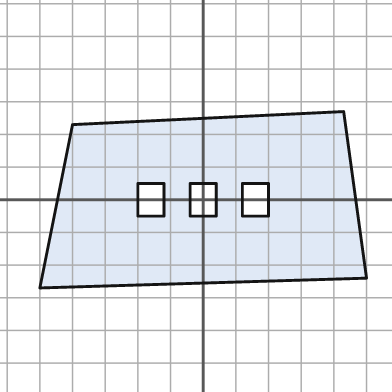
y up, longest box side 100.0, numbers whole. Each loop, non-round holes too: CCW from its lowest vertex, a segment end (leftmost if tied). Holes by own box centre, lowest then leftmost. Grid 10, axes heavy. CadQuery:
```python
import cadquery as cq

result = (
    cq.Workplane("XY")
    .moveTo(-50.0, -27.0)
    .lineTo(50.0, -24.0)
    .lineTo(43.0, 27.0)
    .lineTo(-40.0, 23.0)
    .close()
    .moveTo(-20.0, -5.0)
    .lineTo(-12.0, -5.0)
    .lineTo(-12.0, 5.0)
    .lineTo(-20.0, 5.0)
    .close()
    .moveTo(-4.0, -5.0)
    .lineTo(4.0, -5.0)
    .lineTo(4.0, 5.0)
    .lineTo(-4.0, 5.0)
    .close()
    .moveTo(12.0, -5.0)
    .lineTo(20.0, -5.0)
    .lineTo(20.0, 5.0)
    .lineTo(12.0, 5.0)
    .close()
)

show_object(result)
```